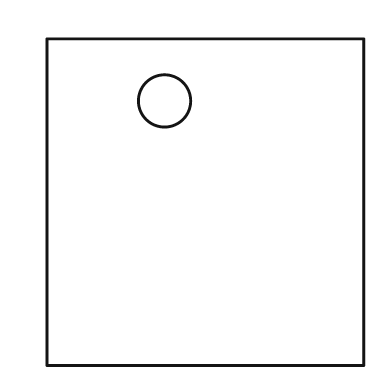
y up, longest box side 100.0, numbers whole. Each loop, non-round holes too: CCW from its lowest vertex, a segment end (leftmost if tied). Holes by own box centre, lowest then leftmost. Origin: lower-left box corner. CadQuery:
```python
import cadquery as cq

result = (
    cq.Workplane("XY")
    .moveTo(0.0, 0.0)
    .lineTo(97.0, 0.0)
    .lineTo(97.0, 100.0)
    .lineTo(0.0, 100.0)
    .close()
    .moveTo(36.0, 81.0)
    .circle(8.0)
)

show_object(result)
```